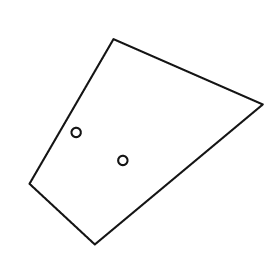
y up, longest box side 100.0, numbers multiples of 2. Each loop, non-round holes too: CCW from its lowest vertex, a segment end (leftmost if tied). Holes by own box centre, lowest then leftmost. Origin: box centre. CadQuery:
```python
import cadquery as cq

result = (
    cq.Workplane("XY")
    .moveTo(-22.0, -44.0)
    .lineTo(50.0, 16.0)
    .lineTo(-14.0, 44.0)
    .lineTo(-50.0, -18.0)
    .close()
    .moveTo(-10.0, -8.0)
    .circle(2.0)
    .moveTo(-30.0, 4.0)
    .circle(2.0)
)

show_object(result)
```